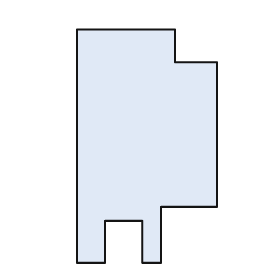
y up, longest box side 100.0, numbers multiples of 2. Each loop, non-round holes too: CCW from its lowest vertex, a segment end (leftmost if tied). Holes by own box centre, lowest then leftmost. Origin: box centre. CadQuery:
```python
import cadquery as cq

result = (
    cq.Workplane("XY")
    .moveTo(-30.0, -50.0)
    .lineTo(-18.0, -50.0)
    .lineTo(-18.0, -32.0)
    .lineTo(-2.0, -32.0)
    .lineTo(-2.0, -50.0)
    .lineTo(6.0, -50.0)
    .lineTo(6.0, -26.0)
    .lineTo(30.0, -26.0)
    .lineTo(30.0, 36.0)
    .lineTo(12.0, 36.0)
    .lineTo(12.0, 50.0)
    .lineTo(-30.0, 50.0)
    .close()
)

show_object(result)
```